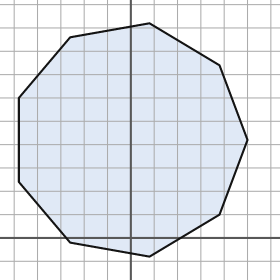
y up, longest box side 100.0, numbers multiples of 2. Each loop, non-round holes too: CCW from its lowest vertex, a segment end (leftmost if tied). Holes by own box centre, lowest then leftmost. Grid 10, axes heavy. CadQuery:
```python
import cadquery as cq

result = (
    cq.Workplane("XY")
    .moveTo(8.0, -8.0)
    .lineTo(38.0, 10.0)
    .lineTo(50.0, 42.0)
    .lineTo(38.0, 74.0)
    .lineTo(8.0, 92.0)
    .lineTo(-26.0, 86.0)
    .lineTo(-48.0, 60.0)
    .lineTo(-48.0, 24.0)
    .lineTo(-26.0, -2.0)
    .close()
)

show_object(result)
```